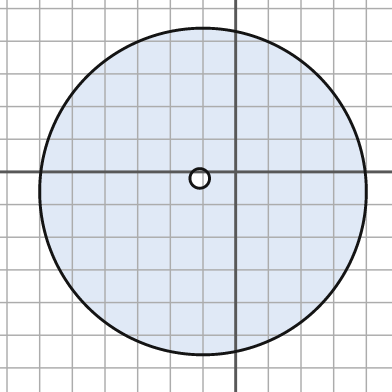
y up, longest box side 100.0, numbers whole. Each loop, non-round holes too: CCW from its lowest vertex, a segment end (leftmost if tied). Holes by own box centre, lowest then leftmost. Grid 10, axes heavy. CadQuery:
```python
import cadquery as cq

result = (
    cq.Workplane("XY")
    .moveTo(-10.0, -6.0)
    .circle(50.0)
    .moveTo(-11.0, -2.0)
    .circle(3.0)
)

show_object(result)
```